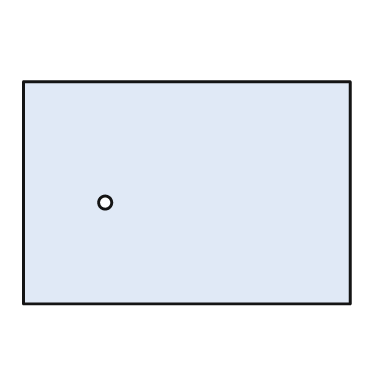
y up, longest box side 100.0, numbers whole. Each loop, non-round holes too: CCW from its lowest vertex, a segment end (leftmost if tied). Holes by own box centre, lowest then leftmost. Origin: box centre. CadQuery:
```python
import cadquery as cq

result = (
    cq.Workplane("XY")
    .moveTo(-50.0, -34.0)
    .lineTo(50.0, -34.0)
    .lineTo(50.0, 34.0)
    .lineTo(-50.0, 34.0)
    .close()
    .moveTo(-25.0, -3.0)
    .circle(2.0)
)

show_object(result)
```